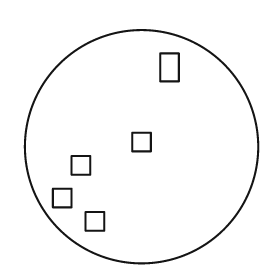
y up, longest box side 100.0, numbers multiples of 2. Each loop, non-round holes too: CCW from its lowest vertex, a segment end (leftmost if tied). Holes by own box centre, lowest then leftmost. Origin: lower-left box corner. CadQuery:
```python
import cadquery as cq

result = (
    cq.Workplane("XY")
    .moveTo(50.0, 50.0)
    .circle(50.0)
    .moveTo(26.0, 14.0)
    .lineTo(34.0, 14.0)
    .lineTo(34.0, 22.0)
    .lineTo(26.0, 22.0)
    .close()
    .moveTo(12.0, 24.0)
    .lineTo(20.0, 24.0)
    .lineTo(20.0, 32.0)
    .lineTo(12.0, 32.0)
    .close()
    .moveTo(20.0, 38.0)
    .lineTo(28.0, 38.0)
    .lineTo(28.0, 46.0)
    .lineTo(20.0, 46.0)
    .close()
    .moveTo(46.0, 48.0)
    .lineTo(54.0, 48.0)
    .lineTo(54.0, 56.0)
    .lineTo(46.0, 56.0)
    .close()
    .moveTo(58.0, 78.0)
    .lineTo(66.0, 78.0)
    .lineTo(66.0, 90.0)
    .lineTo(58.0, 90.0)
    .close()
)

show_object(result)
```